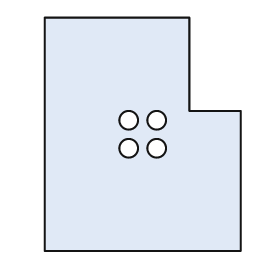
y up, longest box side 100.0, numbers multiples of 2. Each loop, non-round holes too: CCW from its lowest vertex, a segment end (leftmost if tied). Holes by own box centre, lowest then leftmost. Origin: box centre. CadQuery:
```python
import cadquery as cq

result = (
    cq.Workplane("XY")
    .moveTo(-42.0, -50.0)
    .lineTo(42.0, -50.0)
    .lineTo(42.0, 10.0)
    .lineTo(20.0, 10.0)
    .lineTo(20.0, 50.0)
    .lineTo(-42.0, 50.0)
    .close()
    .moveTo(-6.0, -6.0)
    .circle(4.0)
    .moveTo(6.0, -6.0)
    .circle(4.0)
    .moveTo(-6.0, 6.0)
    .circle(4.0)
    .moveTo(6.0, 6.0)
    .circle(4.0)
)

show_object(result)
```